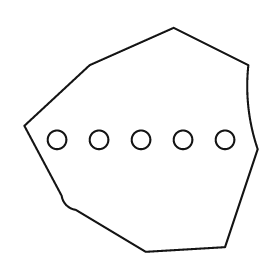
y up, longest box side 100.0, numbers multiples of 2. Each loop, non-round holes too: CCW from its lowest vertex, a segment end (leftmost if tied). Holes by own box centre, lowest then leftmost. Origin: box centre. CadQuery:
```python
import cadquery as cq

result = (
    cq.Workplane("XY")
    .moveTo(2.0, -48.0)
    .lineTo(36.0, -46.0)
    .lineTo(50.0, -4.0)
    .threePointArc((46.0, 14.0), (46.0, 32.0))
    .lineTo(14.0, 48.0)
    .lineTo(-22.0, 32.0)
    .lineTo(-50.0, 6.0)
    .lineTo(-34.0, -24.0)
    .threePointArc((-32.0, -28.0), (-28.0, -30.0))
    .close()
    .moveTo(-36.0, 0.0)
    .circle(4.0)
    .moveTo(-18.0, 0.0)
    .circle(4.0)
    .moveTo(0.0, 0.0)
    .circle(4.0)
    .moveTo(18.0, 0.0)
    .circle(4.0)
    .moveTo(36.0, 0.0)
    .circle(4.0)
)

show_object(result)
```